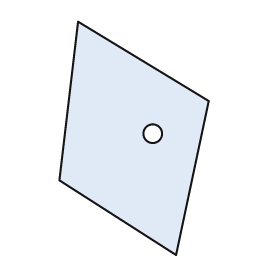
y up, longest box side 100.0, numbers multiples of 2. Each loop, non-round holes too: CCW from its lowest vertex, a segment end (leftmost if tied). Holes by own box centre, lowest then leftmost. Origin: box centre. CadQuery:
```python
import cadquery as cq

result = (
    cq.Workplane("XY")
    .moveTo(18.0, -50.0)
    .lineTo(32.0, 16.0)
    .lineTo(-24.0, 50.0)
    .lineTo(-32.0, -18.0)
    .close()
    .moveTo(8.0, 2.0)
    .circle(4.0)
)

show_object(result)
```